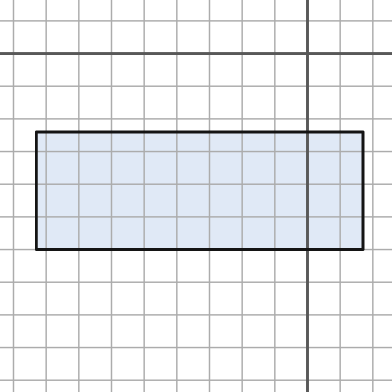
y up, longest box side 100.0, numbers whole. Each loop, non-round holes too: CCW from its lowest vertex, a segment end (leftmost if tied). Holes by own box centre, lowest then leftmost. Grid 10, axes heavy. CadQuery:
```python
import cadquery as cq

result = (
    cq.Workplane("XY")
    .moveTo(-83.0, -60.0)
    .lineTo(17.0, -60.0)
    .lineTo(17.0, -24.0)
    .lineTo(-83.0, -24.0)
    .close()
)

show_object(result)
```